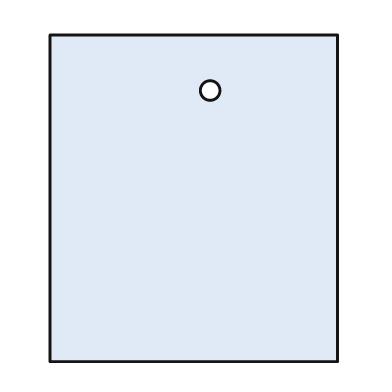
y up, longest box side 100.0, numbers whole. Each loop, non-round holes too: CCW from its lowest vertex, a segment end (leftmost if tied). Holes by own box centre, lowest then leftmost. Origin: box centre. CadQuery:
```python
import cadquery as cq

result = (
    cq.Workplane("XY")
    .moveTo(-44.0, -50.0)
    .lineTo(44.0, -50.0)
    .lineTo(44.0, 50.0)
    .lineTo(-44.0, 50.0)
    .close()
    .moveTo(5.0, 33.0)
    .circle(3.0)
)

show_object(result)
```